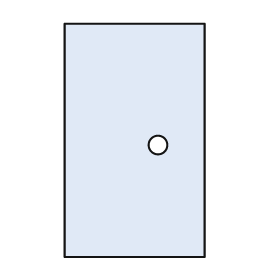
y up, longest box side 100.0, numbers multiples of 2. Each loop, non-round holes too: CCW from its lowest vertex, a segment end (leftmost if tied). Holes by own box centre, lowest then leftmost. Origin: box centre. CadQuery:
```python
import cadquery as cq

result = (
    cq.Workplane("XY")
    .moveTo(-30.0, -50.0)
    .lineTo(30.0, -50.0)
    .lineTo(30.0, 50.0)
    .lineTo(-30.0, 50.0)
    .close()
    .moveTo(10.0, -2.0)
    .circle(4.0)
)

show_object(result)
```